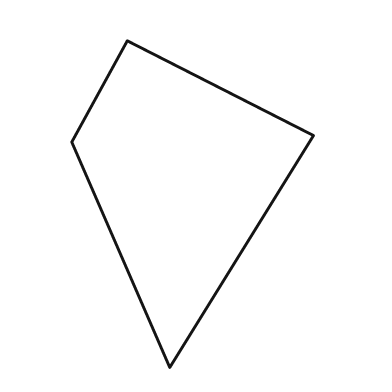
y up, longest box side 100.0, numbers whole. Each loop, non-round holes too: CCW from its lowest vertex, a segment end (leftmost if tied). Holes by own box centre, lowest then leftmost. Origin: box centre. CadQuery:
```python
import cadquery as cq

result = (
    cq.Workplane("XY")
    .moveTo(-7.0, -50.0)
    .lineTo(37.0, 21.0)
    .lineTo(-20.0, 50.0)
    .lineTo(-37.0, 19.0)
    .close()
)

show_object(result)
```